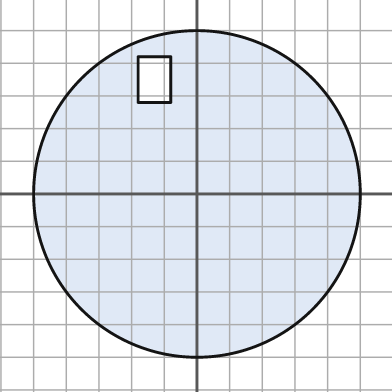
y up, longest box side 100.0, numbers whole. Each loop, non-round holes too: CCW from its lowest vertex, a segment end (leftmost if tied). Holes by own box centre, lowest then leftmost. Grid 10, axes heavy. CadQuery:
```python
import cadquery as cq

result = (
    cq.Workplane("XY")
    .moveTo(0.0, 0.0)
    .circle(50.0)
    .moveTo(-18.0, 28.0)
    .lineTo(-8.0, 28.0)
    .lineTo(-8.0, 42.0)
    .lineTo(-18.0, 42.0)
    .close()
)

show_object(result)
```